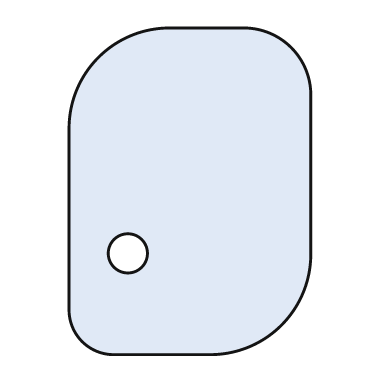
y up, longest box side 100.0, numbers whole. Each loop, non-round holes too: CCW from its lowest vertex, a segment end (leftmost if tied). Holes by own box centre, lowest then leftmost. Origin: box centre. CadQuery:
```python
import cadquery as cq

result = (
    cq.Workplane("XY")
    .moveTo(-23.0, -50.0)
    .lineTo(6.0, -50.0)
    .threePointArc((28.0, -41.0), (37.0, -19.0))
    .lineTo(37.0, 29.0)
    .threePointArc((31.0, 44.0), (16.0, 50.0))
    .lineTo(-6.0, 50.0)
    .threePointArc((-28.0, 41.0), (-37.0, 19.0))
    .lineTo(-37.0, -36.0)
    .threePointArc((-33.0, -46.0), (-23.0, -50.0))
    .close()
    .moveTo(-19.0, -19.0)
    .circle(6.0)
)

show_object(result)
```